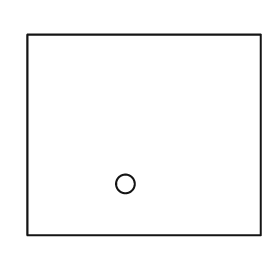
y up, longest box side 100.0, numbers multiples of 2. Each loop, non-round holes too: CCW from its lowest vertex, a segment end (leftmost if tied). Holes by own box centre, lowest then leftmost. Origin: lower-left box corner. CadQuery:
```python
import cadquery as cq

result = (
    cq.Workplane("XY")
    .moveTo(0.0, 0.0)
    .lineTo(100.0, 0.0)
    .lineTo(100.0, 86.0)
    .lineTo(0.0, 86.0)
    .close()
    .moveTo(42.0, 22.0)
    .circle(4.0)
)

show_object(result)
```